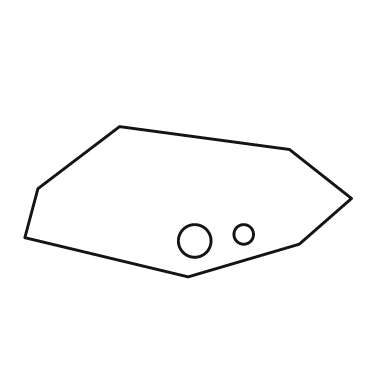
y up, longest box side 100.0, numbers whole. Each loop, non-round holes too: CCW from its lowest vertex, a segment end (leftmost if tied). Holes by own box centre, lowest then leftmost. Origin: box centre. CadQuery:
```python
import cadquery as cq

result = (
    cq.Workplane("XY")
    .moveTo(0.0, -23.0)
    .lineTo(34.0, -13.0)
    .lineTo(50.0, 1.0)
    .lineTo(31.0, 16.0)
    .lineTo(-21.0, 23.0)
    .lineTo(-46.0, 4.0)
    .lineTo(-50.0, -11.0)
    .close()
    .moveTo(2.0, -12.0)
    .circle(5.0)
    .moveTo(17.0, -10.0)
    .circle(3.0)
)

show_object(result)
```